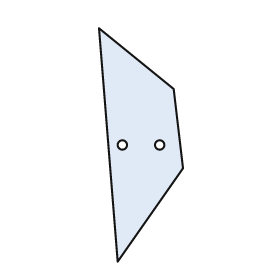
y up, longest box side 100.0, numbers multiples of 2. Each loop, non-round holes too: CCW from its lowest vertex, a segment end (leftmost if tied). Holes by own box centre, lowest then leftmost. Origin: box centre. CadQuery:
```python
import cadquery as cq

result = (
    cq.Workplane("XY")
    .moveTo(-10.0, -50.0)
    .lineTo(18.0, -10.0)
    .lineTo(14.0, 24.0)
    .lineTo(-18.0, 50.0)
    .close()
    .moveTo(-8.0, 0.0)
    .circle(2.0)
    .moveTo(8.0, 0.0)
    .circle(2.0)
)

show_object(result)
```